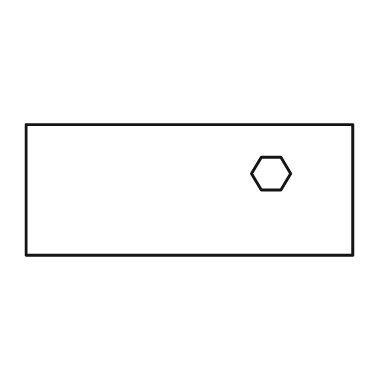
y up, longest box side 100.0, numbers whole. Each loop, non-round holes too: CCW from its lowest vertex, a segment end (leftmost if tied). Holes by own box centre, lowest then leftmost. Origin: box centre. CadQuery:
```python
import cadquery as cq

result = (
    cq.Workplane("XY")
    .moveTo(-50.0, -20.0)
    .lineTo(50.0, -20.0)
    .lineTo(50.0, 20.0)
    .lineTo(-50.0, 20.0)
    .close()
    .moveTo(22.0, 0.0)
    .lineTo(28.0, 0.0)
    .lineTo(31.0, 5.0)
    .lineTo(28.0, 10.0)
    .lineTo(22.0, 10.0)
    .lineTo(19.0, 5.0)
    .close()
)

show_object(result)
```